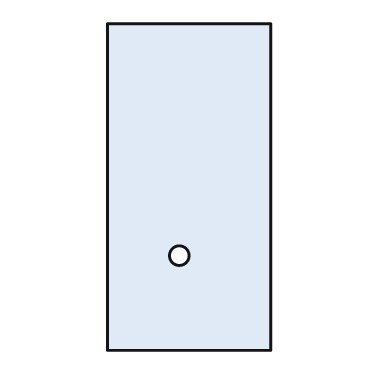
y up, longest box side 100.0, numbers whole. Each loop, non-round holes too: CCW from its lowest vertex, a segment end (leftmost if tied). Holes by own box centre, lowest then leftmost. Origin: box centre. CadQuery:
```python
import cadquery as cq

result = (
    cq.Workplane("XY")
    .moveTo(-25.0, -50.0)
    .lineTo(25.0, -50.0)
    .lineTo(25.0, 50.0)
    .lineTo(-25.0, 50.0)
    .close()
    .moveTo(-3.0, -21.0)
    .circle(3.0)
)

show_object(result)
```